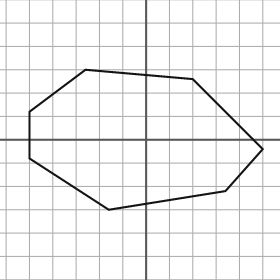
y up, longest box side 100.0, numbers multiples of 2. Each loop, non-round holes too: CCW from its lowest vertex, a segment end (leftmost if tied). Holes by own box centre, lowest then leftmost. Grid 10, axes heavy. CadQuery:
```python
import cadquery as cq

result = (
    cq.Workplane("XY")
    .moveTo(-16.0, -30.0)
    .lineTo(34.0, -22.0)
    .lineTo(50.0, -4.0)
    .lineTo(20.0, 26.0)
    .lineTo(-26.0, 30.0)
    .lineTo(-50.0, 12.0)
    .lineTo(-50.0, -8.0)
    .close()
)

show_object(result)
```